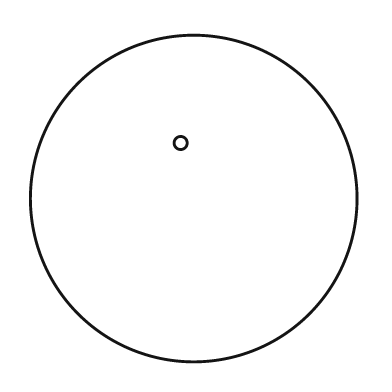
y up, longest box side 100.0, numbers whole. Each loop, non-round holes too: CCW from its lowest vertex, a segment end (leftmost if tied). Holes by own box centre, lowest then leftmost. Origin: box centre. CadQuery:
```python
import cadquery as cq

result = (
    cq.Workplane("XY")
    .moveTo(0.0, 0.0)
    .circle(50.0)
    .moveTo(-4.0, 17.0)
    .circle(2.0)
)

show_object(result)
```